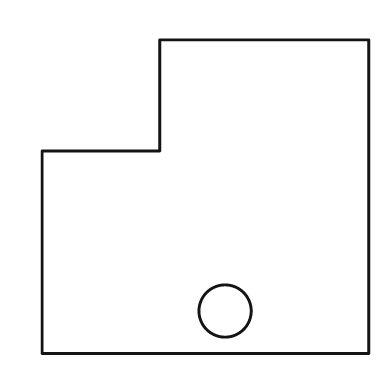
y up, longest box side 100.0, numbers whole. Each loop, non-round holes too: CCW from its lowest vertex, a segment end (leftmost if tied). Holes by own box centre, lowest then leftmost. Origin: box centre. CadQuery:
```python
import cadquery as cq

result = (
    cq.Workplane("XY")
    .moveTo(-50.0, -48.0)
    .lineTo(50.0, -48.0)
    .lineTo(50.0, 48.0)
    .lineTo(-14.0, 48.0)
    .lineTo(-14.0, 14.0)
    .lineTo(-50.0, 14.0)
    .close()
    .moveTo(6.0, -35.0)
    .circle(8.0)
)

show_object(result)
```